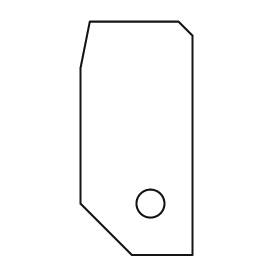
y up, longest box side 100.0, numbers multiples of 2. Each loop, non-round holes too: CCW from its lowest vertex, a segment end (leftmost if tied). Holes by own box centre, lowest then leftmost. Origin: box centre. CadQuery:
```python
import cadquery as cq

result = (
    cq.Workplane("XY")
    .moveTo(-2.0, -50.0)
    .lineTo(24.0, -50.0)
    .lineTo(24.0, 44.0)
    .lineTo(18.0, 50.0)
    .lineTo(-20.0, 50.0)
    .lineTo(-24.0, 30.0)
    .lineTo(-24.0, -28.0)
    .close()
    .moveTo(6.0, -28.0)
    .circle(6.0)
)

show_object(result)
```